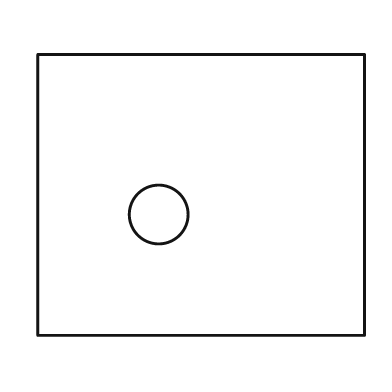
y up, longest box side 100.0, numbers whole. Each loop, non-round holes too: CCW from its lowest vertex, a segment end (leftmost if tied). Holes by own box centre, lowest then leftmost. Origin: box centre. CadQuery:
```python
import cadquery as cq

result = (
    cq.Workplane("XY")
    .moveTo(-50.0, -43.0)
    .lineTo(50.0, -43.0)
    .lineTo(50.0, 43.0)
    .lineTo(-50.0, 43.0)
    .close()
    .moveTo(-13.0, -6.0)
    .circle(9.0)
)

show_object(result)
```